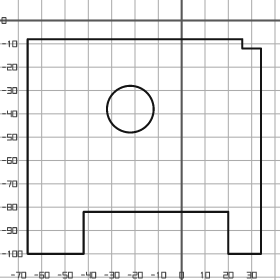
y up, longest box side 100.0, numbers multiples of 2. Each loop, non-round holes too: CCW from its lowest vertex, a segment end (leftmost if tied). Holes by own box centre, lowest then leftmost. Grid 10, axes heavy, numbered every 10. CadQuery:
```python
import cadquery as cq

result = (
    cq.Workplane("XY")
    .moveTo(-66.0, -100.0)
    .lineTo(-42.0, -100.0)
    .lineTo(-42.0, -82.0)
    .lineTo(20.0, -82.0)
    .lineTo(20.0, -100.0)
    .lineTo(34.0, -100.0)
    .lineTo(34.0, -12.0)
    .lineTo(26.0, -12.0)
    .lineTo(26.0, -8.0)
    .lineTo(-66.0, -8.0)
    .close()
    .moveTo(-22.0, -38.0)
    .circle(10.0)
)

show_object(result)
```